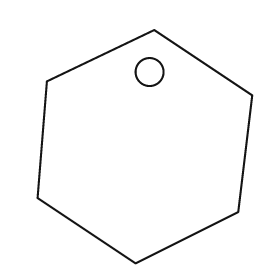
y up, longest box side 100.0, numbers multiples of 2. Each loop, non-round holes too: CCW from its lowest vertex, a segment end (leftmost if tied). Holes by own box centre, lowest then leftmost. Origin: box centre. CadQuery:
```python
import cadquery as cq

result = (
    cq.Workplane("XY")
    .moveTo(-4.0, -50.0)
    .lineTo(40.0, -28.0)
    .lineTo(46.0, 22.0)
    .lineTo(4.0, 50.0)
    .lineTo(-42.0, 28.0)
    .lineTo(-46.0, -22.0)
    .close()
    .moveTo(2.0, 32.0)
    .circle(6.0)
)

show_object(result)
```